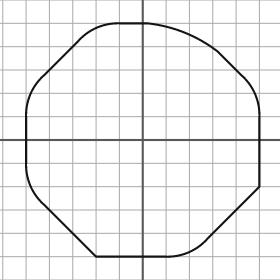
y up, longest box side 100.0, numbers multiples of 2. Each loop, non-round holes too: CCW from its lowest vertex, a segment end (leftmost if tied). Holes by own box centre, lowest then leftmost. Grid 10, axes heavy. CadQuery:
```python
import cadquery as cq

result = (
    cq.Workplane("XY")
    .moveTo(-20.0, -50.0)
    .lineTo(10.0, -50.0)
    .threePointArc((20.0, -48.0), (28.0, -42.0))
    .lineTo(50.0, -20.0)
    .lineTo(50.0, 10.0)
    .threePointArc((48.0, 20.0), (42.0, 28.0))
    .lineTo(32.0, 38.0)
    .threePointArc((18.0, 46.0), (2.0, 50.0))
    .lineTo(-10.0, 50.0)
    .threePointArc((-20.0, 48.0), (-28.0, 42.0))
    .lineTo(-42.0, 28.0)
    .threePointArc((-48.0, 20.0), (-50.0, 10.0))
    .lineTo(-50.0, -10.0)
    .threePointArc((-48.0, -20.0), (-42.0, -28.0))
    .close()
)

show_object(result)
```